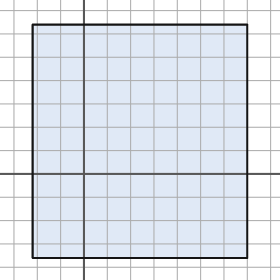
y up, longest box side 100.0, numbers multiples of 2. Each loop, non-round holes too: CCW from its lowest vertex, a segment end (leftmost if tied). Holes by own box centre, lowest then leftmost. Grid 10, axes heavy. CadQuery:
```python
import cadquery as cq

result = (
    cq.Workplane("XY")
    .moveTo(-22.0, -36.0)
    .lineTo(70.0, -36.0)
    .lineTo(70.0, 64.0)
    .lineTo(-22.0, 64.0)
    .close()
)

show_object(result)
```